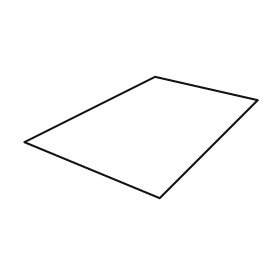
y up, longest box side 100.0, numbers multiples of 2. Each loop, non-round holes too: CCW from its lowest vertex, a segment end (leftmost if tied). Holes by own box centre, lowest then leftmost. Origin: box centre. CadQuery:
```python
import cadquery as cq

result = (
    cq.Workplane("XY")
    .moveTo(8.0, -26.0)
    .lineTo(50.0, 16.0)
    .lineTo(6.0, 26.0)
    .lineTo(-50.0, -2.0)
    .close()
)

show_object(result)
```